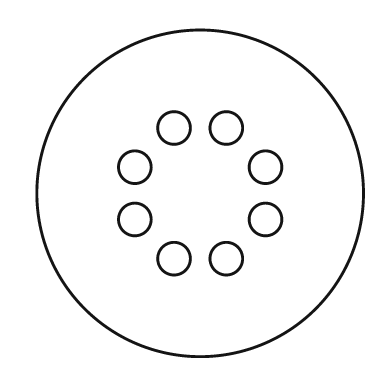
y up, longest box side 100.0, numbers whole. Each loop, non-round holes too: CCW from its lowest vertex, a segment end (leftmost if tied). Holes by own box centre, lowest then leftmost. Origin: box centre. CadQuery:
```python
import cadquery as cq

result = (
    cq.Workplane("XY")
    .moveTo(0.0, 0.0)
    .circle(50.0)
    .moveTo(-8.0, -20.0)
    .circle(5.0)
    .moveTo(8.0, -20.0)
    .circle(5.0)
    .moveTo(-20.0, -8.0)
    .circle(5.0)
    .moveTo(20.0, -8.0)
    .circle(5.0)
    .moveTo(-20.0, 8.0)
    .circle(5.0)
    .moveTo(20.0, 8.0)
    .circle(5.0)
    .moveTo(-8.0, 20.0)
    .circle(5.0)
    .moveTo(8.0, 20.0)
    .circle(5.0)
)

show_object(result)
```